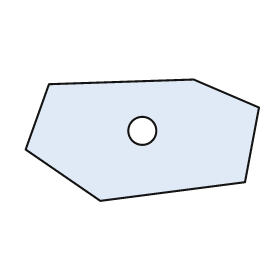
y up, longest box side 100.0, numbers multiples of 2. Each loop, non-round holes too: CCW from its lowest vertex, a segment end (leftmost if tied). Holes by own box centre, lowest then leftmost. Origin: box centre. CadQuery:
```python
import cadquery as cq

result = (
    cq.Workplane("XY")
    .moveTo(-18.0, -26.0)
    .lineTo(44.0, -18.0)
    .lineTo(50.0, 14.0)
    .lineTo(22.0, 26.0)
    .lineTo(-40.0, 24.0)
    .lineTo(-50.0, -4.0)
    .close()
    .moveTo(0.0, 4.0)
    .circle(6.0)
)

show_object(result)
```